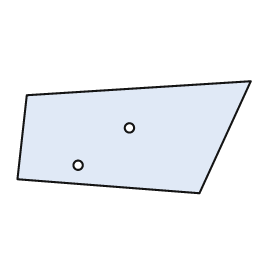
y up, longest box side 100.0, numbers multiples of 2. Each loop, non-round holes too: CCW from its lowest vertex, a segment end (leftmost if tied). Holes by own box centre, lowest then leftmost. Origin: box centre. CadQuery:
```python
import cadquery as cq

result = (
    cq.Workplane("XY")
    .moveTo(28.0, -24.0)
    .lineTo(50.0, 24.0)
    .lineTo(-46.0, 18.0)
    .lineTo(-50.0, -18.0)
    .close()
    .moveTo(-24.0, -12.0)
    .circle(2.0)
    .moveTo(-2.0, 4.0)
    .circle(2.0)
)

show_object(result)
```